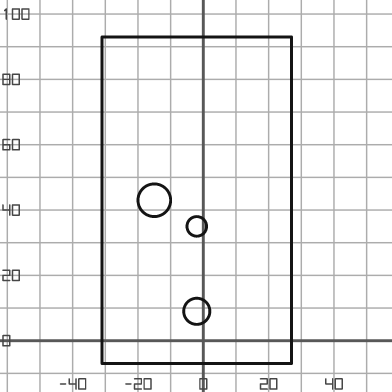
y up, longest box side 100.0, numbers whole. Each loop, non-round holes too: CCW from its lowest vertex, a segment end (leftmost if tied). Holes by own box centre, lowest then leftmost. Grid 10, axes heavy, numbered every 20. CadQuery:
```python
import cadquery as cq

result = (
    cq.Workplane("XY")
    .moveTo(-31.0, -7.0)
    .lineTo(27.0, -7.0)
    .lineTo(27.0, 93.0)
    .lineTo(-31.0, 93.0)
    .close()
    .moveTo(-2.0, 9.0)
    .circle(4.0)
    .moveTo(-2.0, 35.0)
    .circle(3.0)
    .moveTo(-15.0, 43.0)
    .circle(5.0)
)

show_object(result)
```